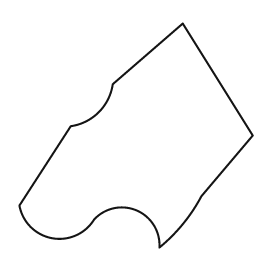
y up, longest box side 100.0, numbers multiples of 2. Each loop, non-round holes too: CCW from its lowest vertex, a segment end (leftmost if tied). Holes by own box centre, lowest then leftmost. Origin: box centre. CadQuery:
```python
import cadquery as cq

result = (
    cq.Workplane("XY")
    .moveTo(10.0, -48.0)
    .threePointArc((20.0, -38.0), (28.0, -26.0))
    .lineTo(50.0, 0.0)
    .lineTo(20.0, 48.0)
    .lineTo(-10.0, 22.0)
    .threePointArc((-16.0, 10.0), (-28.0, 4.0))
    .lineTo(-50.0, -30.0)
    .threePointArc((-36.0, -44.0), (-18.0, -36.0))
    .threePointArc((0.0, -32.0), (10.0, -48.0))
    .close()
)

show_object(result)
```